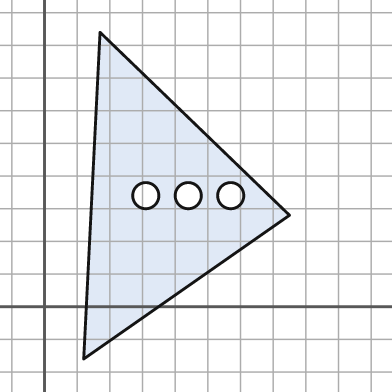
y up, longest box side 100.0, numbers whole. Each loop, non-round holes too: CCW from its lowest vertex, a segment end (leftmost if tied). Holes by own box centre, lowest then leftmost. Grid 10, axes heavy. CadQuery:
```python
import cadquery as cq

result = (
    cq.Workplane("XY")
    .moveTo(12.0, -16.0)
    .lineTo(75.0, 28.0)
    .lineTo(17.0, 84.0)
    .close()
    .moveTo(31.0, 34.0)
    .circle(4.0)
    .moveTo(44.0, 34.0)
    .circle(4.0)
    .moveTo(57.0, 34.0)
    .circle(4.0)
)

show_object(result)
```